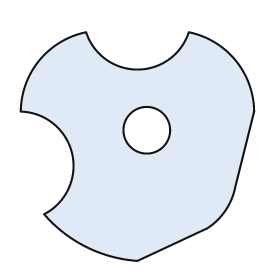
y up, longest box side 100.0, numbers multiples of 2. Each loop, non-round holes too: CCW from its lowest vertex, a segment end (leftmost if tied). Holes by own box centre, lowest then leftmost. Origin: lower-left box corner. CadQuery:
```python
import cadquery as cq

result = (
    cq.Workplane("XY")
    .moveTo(50.0, 0.0)
    .lineTo(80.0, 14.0)
    .threePointArc((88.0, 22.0), (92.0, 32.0))
    .lineTo(100.0, 64.0)
    .threePointArc((92.0, 86.0), (72.0, 98.0))
    .threePointArc((50.0, 82.0), (28.0, 98.0))
    .threePointArc((8.0, 86.0), (0.0, 64.0))
    .threePointArc((22.0, 46.0), (10.0, 20.0))
    .threePointArc((28.0, 6.0), (50.0, 0.0))
    .close()
    .moveTo(54.0, 56.0)
    .circle(10.0)
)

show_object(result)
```